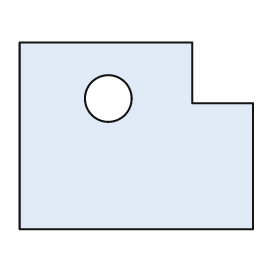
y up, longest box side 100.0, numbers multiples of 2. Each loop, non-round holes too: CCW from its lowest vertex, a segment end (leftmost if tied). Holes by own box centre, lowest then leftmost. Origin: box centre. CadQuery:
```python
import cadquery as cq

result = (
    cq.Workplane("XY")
    .moveTo(-50.0, -40.0)
    .lineTo(50.0, -40.0)
    .lineTo(50.0, 14.0)
    .lineTo(24.0, 14.0)
    .lineTo(24.0, 40.0)
    .lineTo(-50.0, 40.0)
    .close()
    .moveTo(-12.0, 16.0)
    .circle(10.0)
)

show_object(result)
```